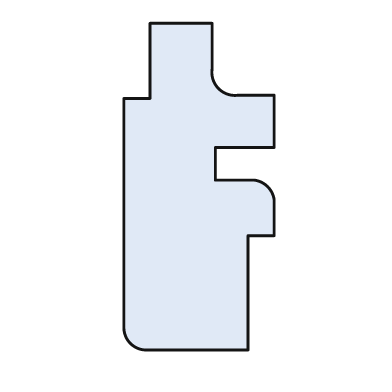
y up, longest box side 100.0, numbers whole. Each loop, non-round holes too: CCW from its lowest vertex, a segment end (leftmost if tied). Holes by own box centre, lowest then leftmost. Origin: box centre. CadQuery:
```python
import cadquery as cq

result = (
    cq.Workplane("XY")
    .moveTo(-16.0, -50.0)
    .lineTo(15.0, -50.0)
    .lineTo(15.0, -15.0)
    .lineTo(23.0, -15.0)
    .lineTo(23.0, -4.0)
    .threePointArc((21.0, 0.0), (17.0, 2.0))
    .lineTo(5.0, 2.0)
    .lineTo(5.0, 12.0)
    .lineTo(23.0, 12.0)
    .lineTo(23.0, 28.0)
    .lineTo(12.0, 28.0)
    .threePointArc((6.0, 30.0), (4.0, 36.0))
    .lineTo(4.0, 50.0)
    .lineTo(-15.0, 50.0)
    .lineTo(-15.0, 27.0)
    .lineTo(-23.0, 27.0)
    .lineTo(-23.0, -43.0)
    .threePointArc((-21.0, -48.0), (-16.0, -50.0))
    .close()
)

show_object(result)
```